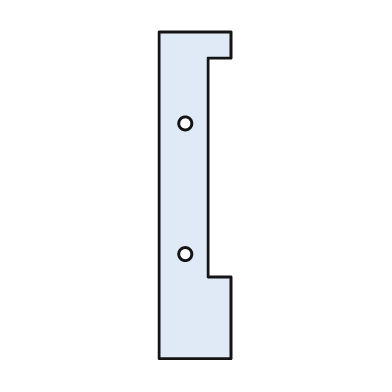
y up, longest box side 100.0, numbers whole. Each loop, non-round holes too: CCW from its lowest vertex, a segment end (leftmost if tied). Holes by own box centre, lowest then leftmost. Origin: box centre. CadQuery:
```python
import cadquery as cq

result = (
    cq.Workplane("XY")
    .moveTo(-11.0, -50.0)
    .lineTo(11.0, -50.0)
    .lineTo(11.0, -25.0)
    .lineTo(4.0, -25.0)
    .lineTo(4.0, 42.0)
    .lineTo(11.0, 42.0)
    .lineTo(11.0, 50.0)
    .lineTo(-11.0, 50.0)
    .close()
    .moveTo(-3.0, -18.0)
    .circle(2.0)
    .moveTo(-3.0, 22.0)
    .circle(2.0)
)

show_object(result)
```